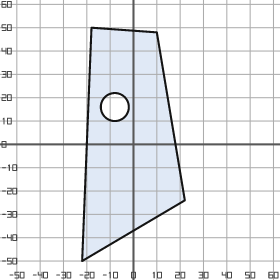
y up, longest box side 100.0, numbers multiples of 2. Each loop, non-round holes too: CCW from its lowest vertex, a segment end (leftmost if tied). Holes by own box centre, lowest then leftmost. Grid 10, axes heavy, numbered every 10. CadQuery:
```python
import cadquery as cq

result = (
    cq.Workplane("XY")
    .moveTo(-22.0, -50.0)
    .lineTo(22.0, -24.0)
    .lineTo(10.0, 48.0)
    .lineTo(-18.0, 50.0)
    .close()
    .moveTo(-8.0, 16.0)
    .circle(6.0)
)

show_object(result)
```